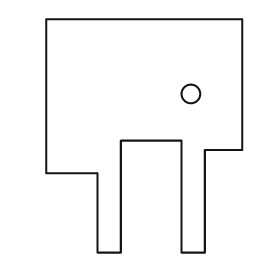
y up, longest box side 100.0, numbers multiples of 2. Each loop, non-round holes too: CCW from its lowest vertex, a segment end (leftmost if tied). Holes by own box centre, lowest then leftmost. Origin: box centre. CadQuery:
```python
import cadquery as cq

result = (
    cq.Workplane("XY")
    .moveTo(-20.0, -50.0)
    .lineTo(-10.0, -50.0)
    .lineTo(-10.0, -2.0)
    .lineTo(16.0, -2.0)
    .lineTo(16.0, -50.0)
    .lineTo(26.0, -50.0)
    .lineTo(26.0, -6.0)
    .lineTo(42.0, -6.0)
    .lineTo(42.0, 50.0)
    .lineTo(-42.0, 50.0)
    .lineTo(-42.0, -16.0)
    .lineTo(-20.0, -16.0)
    .close()
    .moveTo(20.0, 18.0)
    .circle(4.0)
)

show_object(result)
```